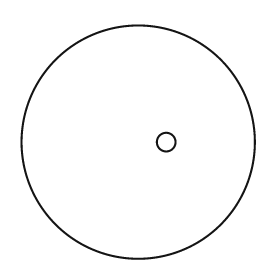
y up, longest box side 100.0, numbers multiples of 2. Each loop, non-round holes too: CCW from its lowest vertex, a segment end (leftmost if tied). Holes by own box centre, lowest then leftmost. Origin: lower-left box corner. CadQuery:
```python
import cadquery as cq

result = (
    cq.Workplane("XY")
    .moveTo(50.0, 50.0)
    .circle(50.0)
    .moveTo(62.0, 50.0)
    .circle(4.0)
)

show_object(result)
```